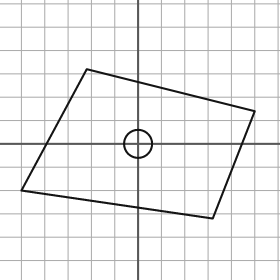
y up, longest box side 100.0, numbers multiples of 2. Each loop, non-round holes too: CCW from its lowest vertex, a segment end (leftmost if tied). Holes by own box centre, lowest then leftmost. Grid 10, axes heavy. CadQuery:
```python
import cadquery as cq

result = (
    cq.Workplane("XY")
    .moveTo(32.0, -32.0)
    .lineTo(50.0, 14.0)
    .lineTo(-22.0, 32.0)
    .lineTo(-50.0, -20.0)
    .close()
    .moveTo(0.0, 0.0)
    .circle(6.0)
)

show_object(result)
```